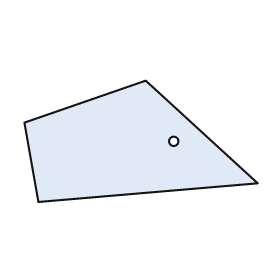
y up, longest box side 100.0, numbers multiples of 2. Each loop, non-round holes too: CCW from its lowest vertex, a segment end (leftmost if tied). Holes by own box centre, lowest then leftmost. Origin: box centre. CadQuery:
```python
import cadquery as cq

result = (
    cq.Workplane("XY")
    .moveTo(-44.0, -26.0)
    .lineTo(50.0, -18.0)
    .lineTo(2.0, 26.0)
    .lineTo(-50.0, 8.0)
    .close()
    .moveTo(14.0, 0.0)
    .circle(2.0)
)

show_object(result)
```